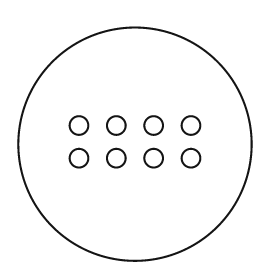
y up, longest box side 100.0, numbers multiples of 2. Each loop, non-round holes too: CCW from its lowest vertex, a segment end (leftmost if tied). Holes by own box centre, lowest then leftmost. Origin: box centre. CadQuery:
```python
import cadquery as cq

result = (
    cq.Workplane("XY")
    .moveTo(0.0, 0.0)
    .circle(50.0)
    .moveTo(-24.0, -6.0)
    .circle(4.0)
    .moveTo(-8.0, -6.0)
    .circle(4.0)
    .moveTo(8.0, -6.0)
    .circle(4.0)
    .moveTo(24.0, -6.0)
    .circle(4.0)
    .moveTo(-24.0, 8.0)
    .circle(4.0)
    .moveTo(-8.0, 8.0)
    .circle(4.0)
    .moveTo(8.0, 8.0)
    .circle(4.0)
    .moveTo(24.0, 8.0)
    .circle(4.0)
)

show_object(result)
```